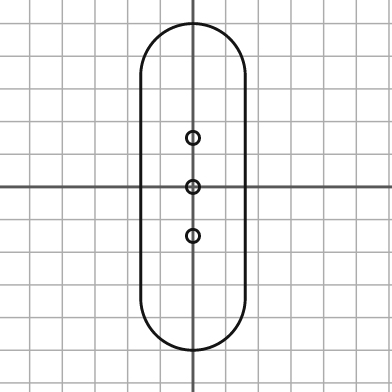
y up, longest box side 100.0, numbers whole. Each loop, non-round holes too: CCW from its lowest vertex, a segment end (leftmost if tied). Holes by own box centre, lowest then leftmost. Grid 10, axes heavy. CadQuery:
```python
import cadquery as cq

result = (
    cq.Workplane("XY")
    .moveTo(-16.0, -34.0)
    .threePointArc((0.0, -50.0), (16.0, -34.0))
    .lineTo(16.0, 34.0)
    .threePointArc((0.0, 50.0), (-16.0, 34.0))
    .close()
    .moveTo(0.0, -15.0)
    .circle(2.0)
    .moveTo(0.0, 0.0)
    .circle(2.0)
    .moveTo(0.0, 15.0)
    .circle(2.0)
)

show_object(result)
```